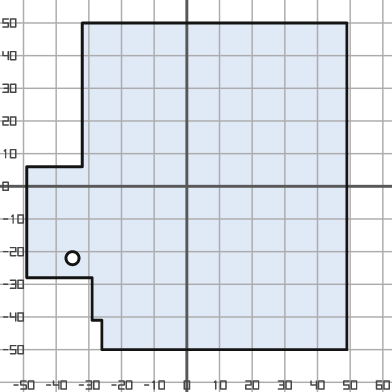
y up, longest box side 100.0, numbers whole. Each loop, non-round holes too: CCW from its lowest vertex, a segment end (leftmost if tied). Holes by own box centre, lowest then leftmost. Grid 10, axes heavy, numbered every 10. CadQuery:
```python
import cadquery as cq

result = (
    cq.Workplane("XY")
    .moveTo(-26.0, -50.0)
    .lineTo(49.0, -50.0)
    .lineTo(49.0, 50.0)
    .lineTo(-32.0, 50.0)
    .lineTo(-32.0, 6.0)
    .lineTo(-49.0, 6.0)
    .lineTo(-49.0, -28.0)
    .lineTo(-29.0, -28.0)
    .lineTo(-29.0, -41.0)
    .lineTo(-26.0, -41.0)
    .close()
    .moveTo(-35.0, -22.0)
    .circle(2.0)
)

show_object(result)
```